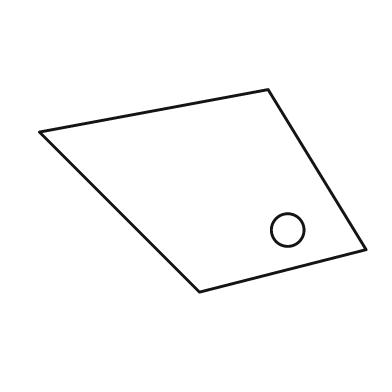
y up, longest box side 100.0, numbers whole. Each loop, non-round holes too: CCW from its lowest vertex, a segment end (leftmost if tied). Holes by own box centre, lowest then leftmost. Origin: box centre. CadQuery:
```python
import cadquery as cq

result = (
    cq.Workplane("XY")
    .moveTo(-1.0, -31.0)
    .lineTo(50.0, -18.0)
    .lineTo(20.0, 31.0)
    .lineTo(-50.0, 18.0)
    .close()
    .moveTo(26.0, -12.0)
    .circle(5.0)
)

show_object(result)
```